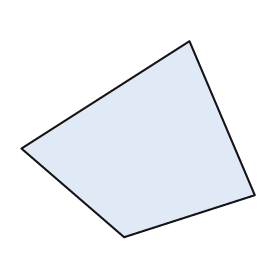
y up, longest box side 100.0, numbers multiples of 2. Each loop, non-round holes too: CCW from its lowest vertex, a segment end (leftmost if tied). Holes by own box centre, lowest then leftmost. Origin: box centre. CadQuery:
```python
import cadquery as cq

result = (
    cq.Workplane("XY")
    .moveTo(-6.0, -42.0)
    .lineTo(50.0, -24.0)
    .lineTo(22.0, 42.0)
    .lineTo(-50.0, -4.0)
    .close()
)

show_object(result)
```